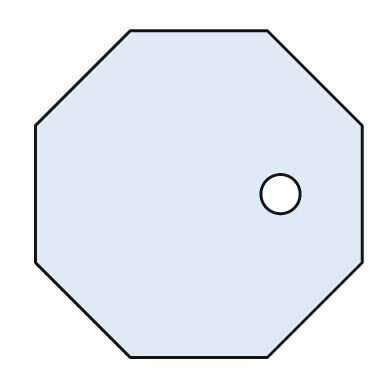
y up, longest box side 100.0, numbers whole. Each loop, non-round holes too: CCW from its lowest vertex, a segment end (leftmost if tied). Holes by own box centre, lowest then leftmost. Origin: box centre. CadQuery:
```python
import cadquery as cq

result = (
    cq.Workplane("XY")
    .moveTo(-21.0, -50.0)
    .lineTo(21.0, -50.0)
    .lineTo(50.0, -21.0)
    .lineTo(50.0, 21.0)
    .lineTo(21.0, 50.0)
    .lineTo(-21.0, 50.0)
    .lineTo(-50.0, 21.0)
    .lineTo(-50.0, -21.0)
    .close()
    .moveTo(25.0, 0.0)
    .circle(6.0)
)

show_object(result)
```